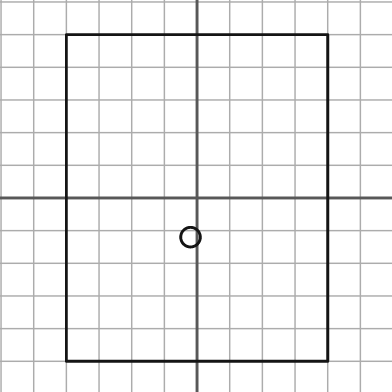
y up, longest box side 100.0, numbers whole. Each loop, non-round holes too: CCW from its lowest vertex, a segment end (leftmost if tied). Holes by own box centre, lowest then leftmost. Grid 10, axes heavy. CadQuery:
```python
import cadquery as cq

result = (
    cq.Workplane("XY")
    .moveTo(-40.0, -50.0)
    .lineTo(40.0, -50.0)
    .lineTo(40.0, 50.0)
    .lineTo(-40.0, 50.0)
    .close()
    .moveTo(-2.0, -12.0)
    .circle(3.0)
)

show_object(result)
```